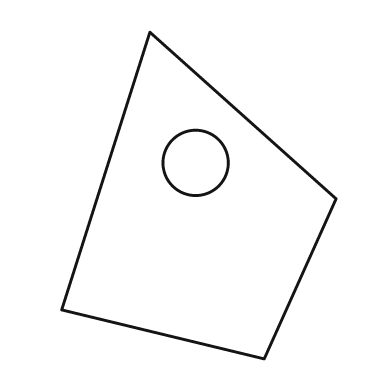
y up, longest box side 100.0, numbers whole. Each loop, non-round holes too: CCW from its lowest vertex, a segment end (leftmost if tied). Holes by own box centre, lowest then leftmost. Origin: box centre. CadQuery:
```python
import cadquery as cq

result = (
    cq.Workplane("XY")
    .moveTo(20.0, -50.0)
    .lineTo(42.0, -1.0)
    .lineTo(-15.0, 50.0)
    .lineTo(-42.0, -35.0)
    .close()
    .moveTo(-1.0, 10.0)
    .circle(10.0)
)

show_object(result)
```